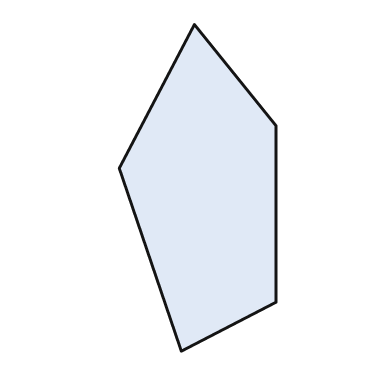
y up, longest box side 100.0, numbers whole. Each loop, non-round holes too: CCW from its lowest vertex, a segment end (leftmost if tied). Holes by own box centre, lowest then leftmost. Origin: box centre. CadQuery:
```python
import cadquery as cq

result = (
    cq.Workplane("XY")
    .moveTo(-5.0, -50.0)
    .lineTo(24.0, -35.0)
    .lineTo(24.0, 19.0)
    .lineTo(-1.0, 50.0)
    .lineTo(-24.0, 6.0)
    .close()
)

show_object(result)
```